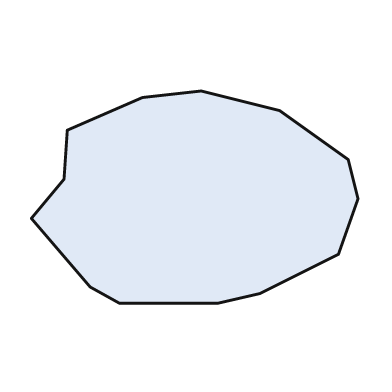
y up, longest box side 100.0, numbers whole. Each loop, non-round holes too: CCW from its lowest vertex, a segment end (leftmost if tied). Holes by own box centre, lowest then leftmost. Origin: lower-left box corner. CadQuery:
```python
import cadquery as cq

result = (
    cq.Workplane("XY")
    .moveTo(27.0, 0.0)
    .lineTo(57.0, 0.0)
    .lineTo(70.0, 3.0)
    .lineTo(94.0, 15.0)
    .lineTo(100.0, 32.0)
    .lineTo(97.0, 44.0)
    .lineTo(76.0, 59.0)
    .lineTo(52.0, 65.0)
    .lineTo(34.0, 63.0)
    .lineTo(11.0, 53.0)
    .lineTo(10.0, 38.0)
    .lineTo(0.0, 26.0)
    .lineTo(18.0, 5.0)
    .close()
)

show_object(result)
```